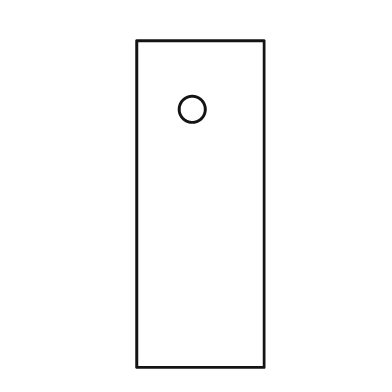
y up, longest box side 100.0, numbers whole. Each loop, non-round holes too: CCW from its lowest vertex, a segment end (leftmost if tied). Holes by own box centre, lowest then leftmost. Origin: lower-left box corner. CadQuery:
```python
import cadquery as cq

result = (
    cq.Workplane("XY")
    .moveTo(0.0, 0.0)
    .lineTo(39.0, 0.0)
    .lineTo(39.0, 100.0)
    .lineTo(0.0, 100.0)
    .close()
    .moveTo(17.0, 79.0)
    .circle(4.0)
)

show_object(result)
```